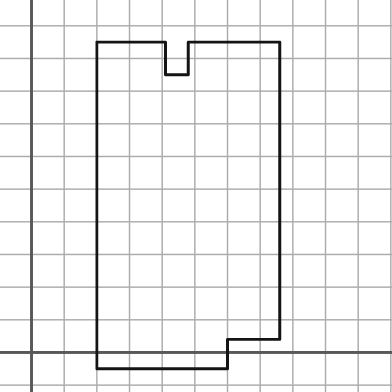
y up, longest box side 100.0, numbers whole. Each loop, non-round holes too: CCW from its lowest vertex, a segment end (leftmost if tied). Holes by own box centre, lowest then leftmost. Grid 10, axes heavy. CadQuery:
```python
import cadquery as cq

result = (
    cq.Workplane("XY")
    .moveTo(20.0, -5.0)
    .lineTo(60.0, -5.0)
    .lineTo(60.0, 4.0)
    .lineTo(76.0, 4.0)
    .lineTo(76.0, 95.0)
    .lineTo(48.0, 95.0)
    .lineTo(48.0, 85.0)
    .lineTo(41.0, 85.0)
    .lineTo(41.0, 95.0)
    .lineTo(20.0, 95.0)
    .close()
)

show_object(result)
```